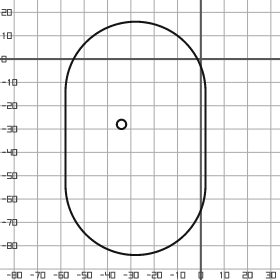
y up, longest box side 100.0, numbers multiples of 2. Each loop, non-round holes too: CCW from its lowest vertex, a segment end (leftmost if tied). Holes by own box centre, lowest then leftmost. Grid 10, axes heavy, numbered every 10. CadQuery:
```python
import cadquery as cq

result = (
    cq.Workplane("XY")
    .moveTo(-58.0, -54.0)
    .threePointArc((-28.0, -84.0), (2.0, -54.0))
    .lineTo(2.0, -14.0)
    .threePointArc((-28.0, 16.0), (-58.0, -14.0))
    .close()
    .moveTo(-34.0, -28.0)
    .circle(2.0)
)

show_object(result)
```